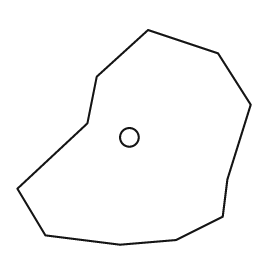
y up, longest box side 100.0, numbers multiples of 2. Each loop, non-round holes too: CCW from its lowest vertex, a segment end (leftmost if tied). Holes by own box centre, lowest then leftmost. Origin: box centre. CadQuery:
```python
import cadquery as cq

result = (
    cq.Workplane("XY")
    .moveTo(-6.0, -46.0)
    .lineTo(18.0, -44.0)
    .lineTo(38.0, -34.0)
    .lineTo(40.0, -18.0)
    .lineTo(50.0, 14.0)
    .lineTo(36.0, 36.0)
    .lineTo(6.0, 46.0)
    .lineTo(-16.0, 26.0)
    .lineTo(-20.0, 6.0)
    .lineTo(-50.0, -22.0)
    .lineTo(-38.0, -42.0)
    .close()
    .moveTo(-2.0, 0.0)
    .circle(4.0)
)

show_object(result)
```